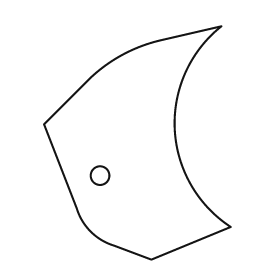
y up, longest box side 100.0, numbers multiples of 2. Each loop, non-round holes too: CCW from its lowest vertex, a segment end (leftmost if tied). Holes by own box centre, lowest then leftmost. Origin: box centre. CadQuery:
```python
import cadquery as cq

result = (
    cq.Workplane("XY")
    .moveTo(6.0, -50.0)
    .lineTo(40.0, -36.0)
    .threePointArc((16.0, 6.0), (36.0, 50.0))
    .lineTo(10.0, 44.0)
    .threePointArc((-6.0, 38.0), (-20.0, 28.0))
    .lineTo(-40.0, 8.0)
    .lineTo(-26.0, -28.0)
    .threePointArc((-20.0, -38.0), (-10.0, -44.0))
    .close()
    .moveTo(-16.0, -14.0)
    .circle(4.0)
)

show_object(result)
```